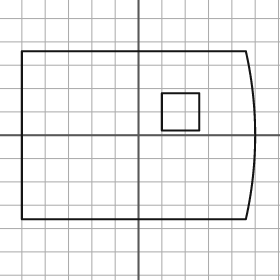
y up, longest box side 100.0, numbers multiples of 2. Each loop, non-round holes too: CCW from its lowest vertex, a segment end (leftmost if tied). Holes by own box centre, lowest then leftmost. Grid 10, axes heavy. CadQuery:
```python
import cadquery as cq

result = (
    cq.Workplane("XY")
    .moveTo(-50.0, -36.0)
    .lineTo(46.0, -36.0)
    .threePointArc((50.0, 0.0), (46.0, 36.0))
    .lineTo(-50.0, 36.0)
    .close()
    .moveTo(10.0, 2.0)
    .lineTo(26.0, 2.0)
    .lineTo(26.0, 18.0)
    .lineTo(10.0, 18.0)
    .close()
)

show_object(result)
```